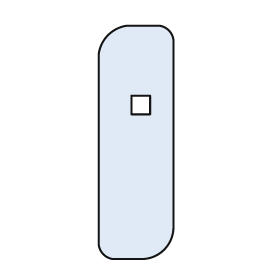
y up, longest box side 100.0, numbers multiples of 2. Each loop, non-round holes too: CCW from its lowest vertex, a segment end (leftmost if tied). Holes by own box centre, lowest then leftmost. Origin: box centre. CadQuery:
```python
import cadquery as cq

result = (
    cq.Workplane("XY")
    .moveTo(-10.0, -50.0)
    .lineTo(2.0, -50.0)
    .threePointArc((12.0, -46.0), (16.0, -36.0))
    .lineTo(16.0, 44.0)
    .threePointArc((14.0, 48.0), (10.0, 50.0))
    .lineTo(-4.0, 50.0)
    .threePointArc((-12.0, 46.0), (-16.0, 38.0))
    .lineTo(-16.0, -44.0)
    .threePointArc((-14.0, -48.0), (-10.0, -50.0))
    .close()
    .moveTo(-2.0, 12.0)
    .lineTo(6.0, 12.0)
    .lineTo(6.0, 20.0)
    .lineTo(-2.0, 20.0)
    .close()
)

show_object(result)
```